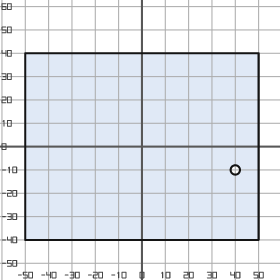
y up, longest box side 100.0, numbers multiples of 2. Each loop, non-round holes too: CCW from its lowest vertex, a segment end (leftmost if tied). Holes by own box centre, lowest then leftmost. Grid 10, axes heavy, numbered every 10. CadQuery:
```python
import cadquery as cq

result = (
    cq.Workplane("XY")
    .moveTo(-50.0, -40.0)
    .lineTo(50.0, -40.0)
    .lineTo(50.0, 40.0)
    .lineTo(-50.0, 40.0)
    .close()
    .moveTo(40.0, -10.0)
    .circle(2.0)
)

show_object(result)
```